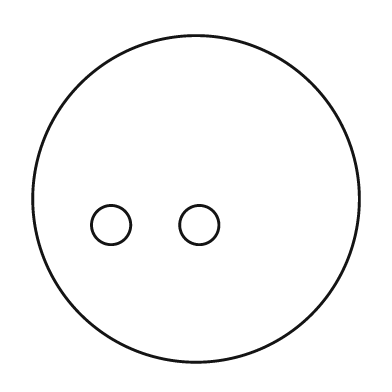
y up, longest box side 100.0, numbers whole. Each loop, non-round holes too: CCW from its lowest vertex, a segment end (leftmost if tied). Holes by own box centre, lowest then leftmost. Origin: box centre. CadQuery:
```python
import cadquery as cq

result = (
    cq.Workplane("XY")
    .moveTo(0.0, 0.0)
    .circle(50.0)
    .moveTo(-26.0, -8.0)
    .circle(6.0)
    .moveTo(1.0, -8.0)
    .circle(6.0)
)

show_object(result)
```